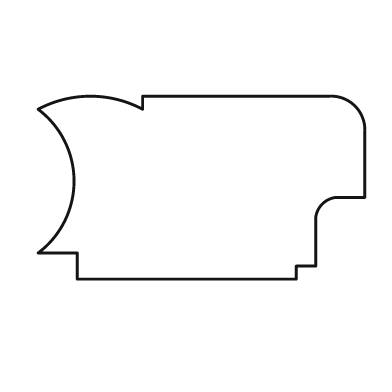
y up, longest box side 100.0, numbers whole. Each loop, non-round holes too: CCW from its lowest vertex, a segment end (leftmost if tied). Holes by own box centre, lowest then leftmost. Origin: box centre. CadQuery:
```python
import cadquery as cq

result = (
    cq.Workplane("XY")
    .moveTo(-38.0, -28.0)
    .lineTo(29.0, -28.0)
    .lineTo(29.0, -24.0)
    .lineTo(35.0, -24.0)
    .lineTo(35.0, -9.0)
    .threePointArc((37.0, -5.0), (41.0, -3.0))
    .lineTo(50.0, -3.0)
    .lineTo(50.0, 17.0)
    .threePointArc((47.0, 25.0), (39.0, 28.0))
    .lineTo(-18.0, 28.0)
    .lineTo(-18.0, 24.0)
    .threePointArc((-34.0, 28.0), (-50.0, 24.0))
    .threePointArc((-39.0, 2.0), (-50.0, -20.0))
    .lineTo(-38.0, -20.0)
    .close()
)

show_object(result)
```